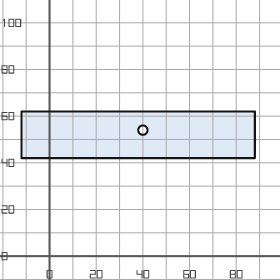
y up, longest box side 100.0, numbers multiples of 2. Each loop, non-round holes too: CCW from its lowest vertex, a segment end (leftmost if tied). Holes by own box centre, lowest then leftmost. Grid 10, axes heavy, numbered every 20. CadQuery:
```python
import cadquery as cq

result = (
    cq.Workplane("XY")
    .moveTo(-12.0, 42.0)
    .lineTo(88.0, 42.0)
    .lineTo(88.0, 62.0)
    .lineTo(-12.0, 62.0)
    .close()
    .moveTo(40.0, 54.0)
    .circle(2.0)
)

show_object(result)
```